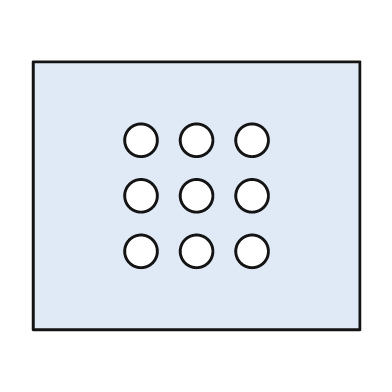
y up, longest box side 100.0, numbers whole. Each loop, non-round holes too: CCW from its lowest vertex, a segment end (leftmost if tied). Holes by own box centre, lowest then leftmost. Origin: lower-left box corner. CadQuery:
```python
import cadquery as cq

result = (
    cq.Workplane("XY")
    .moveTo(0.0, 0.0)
    .lineTo(100.0, 0.0)
    .lineTo(100.0, 82.0)
    .lineTo(0.0, 82.0)
    .close()
    .moveTo(33.0, 24.0)
    .circle(5.0)
    .moveTo(50.0, 24.0)
    .circle(5.0)
    .moveTo(67.0, 24.0)
    .circle(5.0)
    .moveTo(33.0, 41.0)
    .circle(5.0)
    .moveTo(50.0, 41.0)
    .circle(5.0)
    .moveTo(67.0, 41.0)
    .circle(5.0)
    .moveTo(33.0, 58.0)
    .circle(5.0)
    .moveTo(50.0, 58.0)
    .circle(5.0)
    .moveTo(67.0, 58.0)
    .circle(5.0)
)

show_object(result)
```